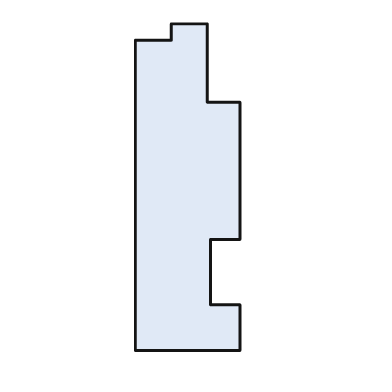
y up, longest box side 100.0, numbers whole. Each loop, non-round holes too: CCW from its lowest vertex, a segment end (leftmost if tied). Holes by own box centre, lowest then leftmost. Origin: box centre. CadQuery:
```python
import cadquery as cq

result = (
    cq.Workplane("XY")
    .moveTo(-16.0, -50.0)
    .lineTo(16.0, -50.0)
    .lineTo(16.0, -36.0)
    .lineTo(7.0, -36.0)
    .lineTo(7.0, -16.0)
    .lineTo(16.0, -16.0)
    .lineTo(16.0, 26.0)
    .lineTo(6.0, 26.0)
    .lineTo(6.0, 50.0)
    .lineTo(-5.0, 50.0)
    .lineTo(-5.0, 45.0)
    .lineTo(-16.0, 45.0)
    .close()
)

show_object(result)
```